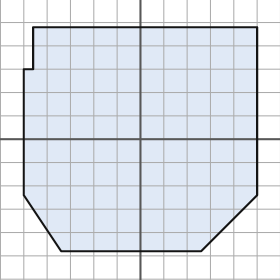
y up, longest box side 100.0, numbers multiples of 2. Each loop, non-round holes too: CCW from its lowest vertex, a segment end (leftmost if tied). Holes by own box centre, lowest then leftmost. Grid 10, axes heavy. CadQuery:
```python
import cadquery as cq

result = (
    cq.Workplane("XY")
    .moveTo(-34.0, -48.0)
    .lineTo(26.0, -48.0)
    .lineTo(50.0, -24.0)
    .lineTo(50.0, 48.0)
    .lineTo(-46.0, 48.0)
    .lineTo(-46.0, 30.0)
    .lineTo(-50.0, 30.0)
    .lineTo(-50.0, -24.0)
    .close()
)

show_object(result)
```